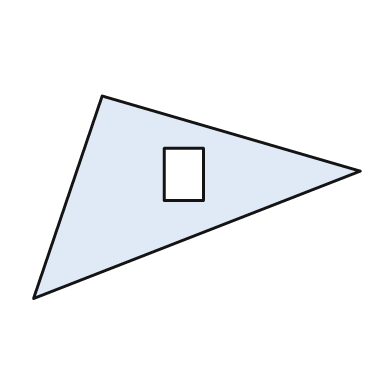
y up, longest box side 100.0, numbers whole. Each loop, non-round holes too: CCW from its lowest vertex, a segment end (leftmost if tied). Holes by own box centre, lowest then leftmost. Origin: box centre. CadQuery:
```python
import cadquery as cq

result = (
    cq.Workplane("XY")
    .moveTo(-50.0, -31.0)
    .lineTo(50.0, 8.0)
    .lineTo(-29.0, 31.0)
    .close()
    .moveTo(-10.0, -1.0)
    .lineTo(2.0, -1.0)
    .lineTo(2.0, 15.0)
    .lineTo(-10.0, 15.0)
    .close()
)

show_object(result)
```